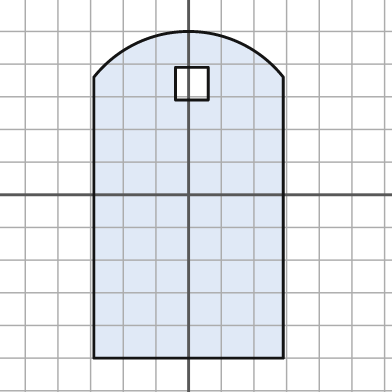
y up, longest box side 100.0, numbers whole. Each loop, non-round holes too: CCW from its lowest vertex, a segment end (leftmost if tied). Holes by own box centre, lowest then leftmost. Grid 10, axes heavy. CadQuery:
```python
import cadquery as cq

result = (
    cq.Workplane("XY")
    .moveTo(-29.0, -50.0)
    .lineTo(29.0, -50.0)
    .lineTo(29.0, 36.0)
    .threePointArc((0.0, 50.0), (-29.0, 36.0))
    .close()
    .moveTo(-4.0, 29.0)
    .lineTo(6.0, 29.0)
    .lineTo(6.0, 39.0)
    .lineTo(-4.0, 39.0)
    .close()
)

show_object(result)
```